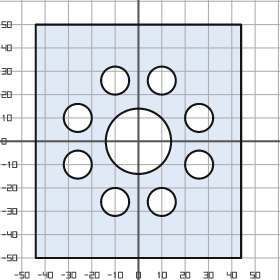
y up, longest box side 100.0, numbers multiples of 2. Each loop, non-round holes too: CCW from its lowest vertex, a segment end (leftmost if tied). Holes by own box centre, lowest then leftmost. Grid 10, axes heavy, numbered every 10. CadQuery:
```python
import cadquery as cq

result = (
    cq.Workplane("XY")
    .moveTo(-44.0, -50.0)
    .lineTo(44.0, -50.0)
    .lineTo(44.0, 50.0)
    .lineTo(-44.0, 50.0)
    .close()
    .moveTo(-10.0, -26.0)
    .circle(6.0)
    .moveTo(10.0, -26.0)
    .circle(6.0)
    .moveTo(-26.0, -10.0)
    .circle(6.0)
    .moveTo(26.0, -10.0)
    .circle(6.0)
    .moveTo(0.0, 0.0)
    .circle(14.0)
    .moveTo(-26.0, 10.0)
    .circle(6.0)
    .moveTo(26.0, 10.0)
    .circle(6.0)
    .moveTo(-10.0, 26.0)
    .circle(6.0)
    .moveTo(10.0, 26.0)
    .circle(6.0)
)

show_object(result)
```